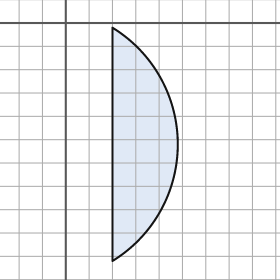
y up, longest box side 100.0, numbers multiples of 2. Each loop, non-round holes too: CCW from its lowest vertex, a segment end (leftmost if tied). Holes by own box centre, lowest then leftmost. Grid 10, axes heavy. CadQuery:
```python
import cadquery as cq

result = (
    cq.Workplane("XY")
    .moveTo(20.0, -102.0)
    .threePointArc((48.0, -52.0), (20.0, -2.0))
    .close()
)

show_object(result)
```